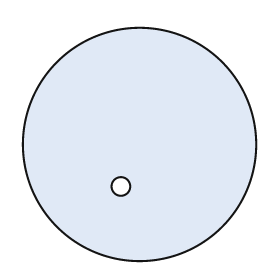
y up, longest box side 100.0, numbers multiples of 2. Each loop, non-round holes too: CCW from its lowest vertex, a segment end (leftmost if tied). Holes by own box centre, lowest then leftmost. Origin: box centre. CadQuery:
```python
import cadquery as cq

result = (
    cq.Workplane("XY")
    .moveTo(0.0, 0.0)
    .circle(50.0)
    .moveTo(-8.0, -18.0)
    .circle(4.0)
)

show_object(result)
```